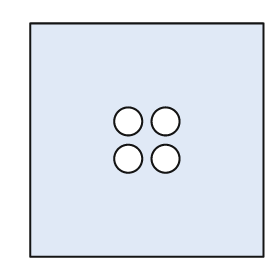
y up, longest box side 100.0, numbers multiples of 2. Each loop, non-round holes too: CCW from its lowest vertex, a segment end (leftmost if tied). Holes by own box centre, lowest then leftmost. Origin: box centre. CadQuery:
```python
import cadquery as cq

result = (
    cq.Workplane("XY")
    .moveTo(-50.0, -50.0)
    .lineTo(50.0, -50.0)
    .lineTo(50.0, 50.0)
    .lineTo(-50.0, 50.0)
    .close()
    .moveTo(-8.0, -8.0)
    .circle(6.0)
    .moveTo(8.0, -8.0)
    .circle(6.0)
    .moveTo(-8.0, 8.0)
    .circle(6.0)
    .moveTo(8.0, 8.0)
    .circle(6.0)
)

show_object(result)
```